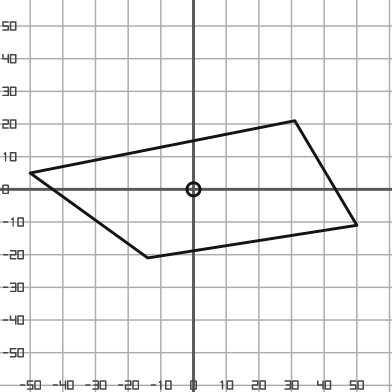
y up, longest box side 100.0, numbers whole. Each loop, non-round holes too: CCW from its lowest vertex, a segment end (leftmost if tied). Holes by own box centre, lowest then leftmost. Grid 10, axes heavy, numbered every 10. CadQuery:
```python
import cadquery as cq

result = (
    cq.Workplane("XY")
    .moveTo(-14.0, -21.0)
    .lineTo(50.0, -11.0)
    .lineTo(31.0, 21.0)
    .lineTo(-50.0, 5.0)
    .close()
    .moveTo(0.0, 0.0)
    .circle(2.0)
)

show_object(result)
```